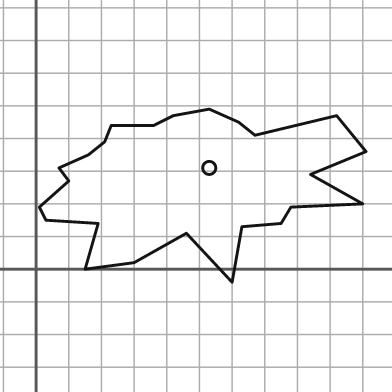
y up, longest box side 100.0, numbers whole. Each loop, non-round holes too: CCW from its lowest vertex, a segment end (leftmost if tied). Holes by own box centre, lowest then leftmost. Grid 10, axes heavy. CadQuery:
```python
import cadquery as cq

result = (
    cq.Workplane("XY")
    .moveTo(60.0, -4.0)
    .lineTo(63.0, 13.0)
    .lineTo(75.0, 14.0)
    .lineTo(78.0, 19.0)
    .lineTo(100.0, 20.0)
    .lineTo(84.0, 29.0)
    .lineTo(101.0, 36.0)
    .lineTo(92.0, 47.0)
    .lineTo(67.0, 41.0)
    .lineTo(62.0, 45.0)
    .lineTo(53.0, 49.0)
    .lineTo(42.0, 47.0)
    .lineTo(36.0, 44.0)
    .lineTo(23.0, 44.0)
    .lineTo(21.0, 39.0)
    .lineTo(16.0, 35.0)
    .lineTo(7.0, 31.0)
    .lineTo(10.0, 27.0)
    .lineTo(1.0, 19.0)
    .lineTo(3.0, 15.0)
    .lineTo(19.0, 14.0)
    .lineTo(15.0, 0.0)
    .lineTo(30.0, 2.0)
    .lineTo(46.0, 11.0)
    .close()
    .moveTo(53.0, 31.0)
    .circle(2.0)
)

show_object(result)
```